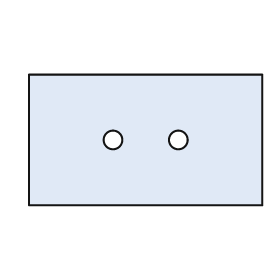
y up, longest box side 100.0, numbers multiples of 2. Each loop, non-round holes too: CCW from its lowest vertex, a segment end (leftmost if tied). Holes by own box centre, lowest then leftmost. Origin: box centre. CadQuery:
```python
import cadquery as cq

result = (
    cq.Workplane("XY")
    .moveTo(-50.0, -28.0)
    .lineTo(50.0, -28.0)
    .lineTo(50.0, 28.0)
    .lineTo(-50.0, 28.0)
    .close()
    .moveTo(-14.0, 0.0)
    .circle(4.0)
    .moveTo(14.0, 0.0)
    .circle(4.0)
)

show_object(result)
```